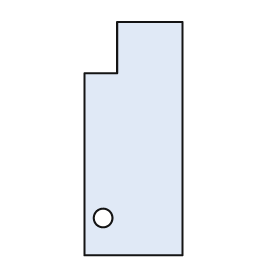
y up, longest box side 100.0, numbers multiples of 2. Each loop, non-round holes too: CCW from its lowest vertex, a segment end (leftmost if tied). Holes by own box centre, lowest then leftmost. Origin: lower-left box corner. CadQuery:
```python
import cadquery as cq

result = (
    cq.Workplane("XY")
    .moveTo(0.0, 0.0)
    .lineTo(42.0, 0.0)
    .lineTo(42.0, 100.0)
    .lineTo(14.0, 100.0)
    .lineTo(14.0, 78.0)
    .lineTo(0.0, 78.0)
    .close()
    .moveTo(8.0, 16.0)
    .circle(4.0)
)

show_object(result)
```